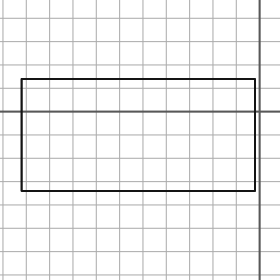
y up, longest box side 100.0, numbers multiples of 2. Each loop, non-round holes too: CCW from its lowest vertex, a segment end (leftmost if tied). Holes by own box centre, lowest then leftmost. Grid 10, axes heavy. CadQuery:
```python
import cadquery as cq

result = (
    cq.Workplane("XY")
    .moveTo(-102.0, -34.0)
    .lineTo(-2.0, -34.0)
    .lineTo(-2.0, 14.0)
    .lineTo(-102.0, 14.0)
    .close()
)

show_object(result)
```